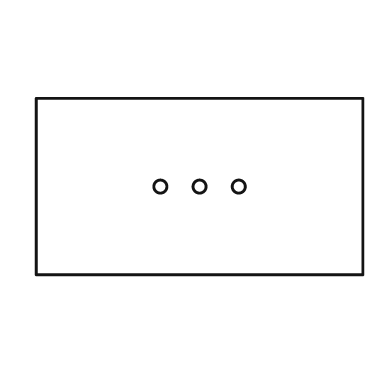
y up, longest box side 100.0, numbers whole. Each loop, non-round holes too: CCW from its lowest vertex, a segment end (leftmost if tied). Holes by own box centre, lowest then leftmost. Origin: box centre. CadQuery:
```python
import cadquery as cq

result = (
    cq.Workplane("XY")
    .moveTo(-50.0, -27.0)
    .lineTo(50.0, -27.0)
    .lineTo(50.0, 27.0)
    .lineTo(-50.0, 27.0)
    .close()
    .moveTo(-12.0, 0.0)
    .circle(2.0)
    .moveTo(0.0, 0.0)
    .circle(2.0)
    .moveTo(12.0, 0.0)
    .circle(2.0)
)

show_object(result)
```